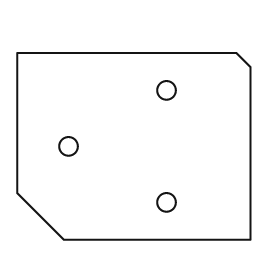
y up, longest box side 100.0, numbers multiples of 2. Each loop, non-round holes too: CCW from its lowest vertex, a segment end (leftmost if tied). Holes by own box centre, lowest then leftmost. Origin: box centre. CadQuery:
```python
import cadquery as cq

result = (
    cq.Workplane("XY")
    .moveTo(-30.0, -40.0)
    .lineTo(50.0, -40.0)
    .lineTo(50.0, 34.0)
    .lineTo(44.0, 40.0)
    .lineTo(-50.0, 40.0)
    .lineTo(-50.0, -20.0)
    .close()
    .moveTo(14.0, -24.0)
    .circle(4.0)
    .moveTo(-28.0, 0.0)
    .circle(4.0)
    .moveTo(14.0, 24.0)
    .circle(4.0)
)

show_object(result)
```